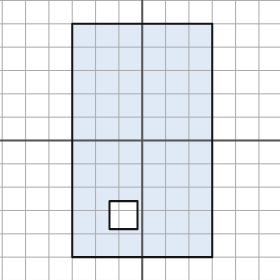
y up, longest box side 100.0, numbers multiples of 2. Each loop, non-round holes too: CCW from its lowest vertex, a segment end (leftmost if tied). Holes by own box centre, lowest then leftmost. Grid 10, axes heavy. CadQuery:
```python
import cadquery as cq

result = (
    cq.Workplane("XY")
    .moveTo(-30.0, -50.0)
    .lineTo(30.0, -50.0)
    .lineTo(30.0, 50.0)
    .lineTo(-30.0, 50.0)
    .close()
    .moveTo(-14.0, -38.0)
    .lineTo(-2.0, -38.0)
    .lineTo(-2.0, -26.0)
    .lineTo(-14.0, -26.0)
    .close()
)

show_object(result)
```